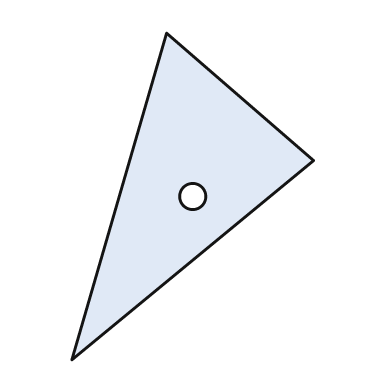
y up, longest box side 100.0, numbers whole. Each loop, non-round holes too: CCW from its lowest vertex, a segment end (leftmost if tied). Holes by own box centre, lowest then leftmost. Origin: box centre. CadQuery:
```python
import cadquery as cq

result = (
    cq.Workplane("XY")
    .moveTo(-37.0, -50.0)
    .lineTo(37.0, 11.0)
    .lineTo(-8.0, 50.0)
    .close()
    .moveTo(0.0, 0.0)
    .circle(4.0)
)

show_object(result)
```